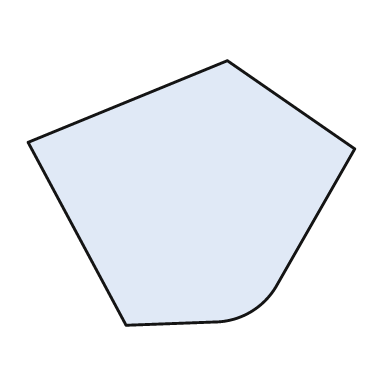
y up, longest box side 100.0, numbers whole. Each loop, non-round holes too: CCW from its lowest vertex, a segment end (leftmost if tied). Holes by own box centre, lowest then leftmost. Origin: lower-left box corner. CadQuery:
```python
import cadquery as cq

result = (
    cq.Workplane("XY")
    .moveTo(30.0, 0.0)
    .lineTo(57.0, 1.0)
    .threePointArc((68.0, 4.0), (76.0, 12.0))
    .lineTo(100.0, 54.0)
    .lineTo(61.0, 81.0)
    .lineTo(0.0, 56.0)
    .close()
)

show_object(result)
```